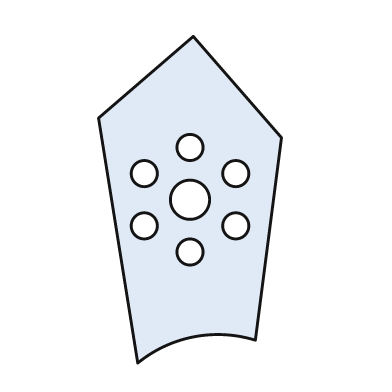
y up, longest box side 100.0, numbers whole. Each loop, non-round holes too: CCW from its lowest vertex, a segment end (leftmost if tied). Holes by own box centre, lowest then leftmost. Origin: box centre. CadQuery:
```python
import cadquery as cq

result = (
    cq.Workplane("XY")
    .moveTo(-16.0, -50.0)
    .threePointArc((1.0, -42.0), (20.0, -43.0))
    .lineTo(28.0, 19.0)
    .lineTo(1.0, 50.0)
    .lineTo(-28.0, 25.0)
    .close()
    .moveTo(0.0, -16.0)
    .circle(4.0)
    .moveTo(-14.0, -8.0)
    .circle(4.0)
    .moveTo(14.0, -8.0)
    .circle(4.0)
    .moveTo(0.0, 0.0)
    .circle(6.0)
    .moveTo(-14.0, 8.0)
    .circle(4.0)
    .moveTo(14.0, 8.0)
    .circle(4.0)
    .moveTo(0.0, 16.0)
    .circle(4.0)
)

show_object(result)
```